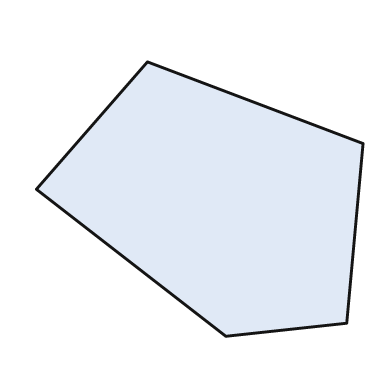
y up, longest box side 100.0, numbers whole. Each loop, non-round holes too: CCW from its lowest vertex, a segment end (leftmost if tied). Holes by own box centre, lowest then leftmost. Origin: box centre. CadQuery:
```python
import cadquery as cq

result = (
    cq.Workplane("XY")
    .moveTo(8.0, -42.0)
    .lineTo(45.0, -38.0)
    .lineTo(50.0, 17.0)
    .lineTo(-16.0, 42.0)
    .lineTo(-50.0, 3.0)
    .close()
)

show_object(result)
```